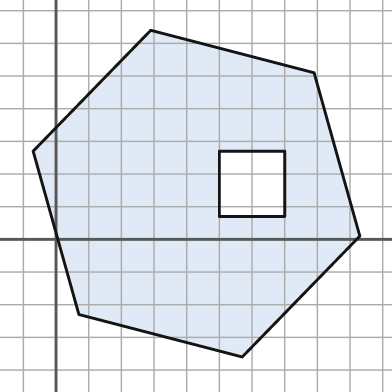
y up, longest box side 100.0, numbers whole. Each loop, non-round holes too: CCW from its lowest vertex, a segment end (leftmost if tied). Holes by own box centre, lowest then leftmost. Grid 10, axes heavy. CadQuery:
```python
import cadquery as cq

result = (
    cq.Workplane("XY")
    .moveTo(57.0, -36.0)
    .lineTo(93.0, 1.0)
    .lineTo(79.0, 51.0)
    .lineTo(29.0, 64.0)
    .lineTo(-7.0, 27.0)
    .lineTo(7.0, -23.0)
    .close()
    .moveTo(50.0, 7.0)
    .lineTo(70.0, 7.0)
    .lineTo(70.0, 27.0)
    .lineTo(50.0, 27.0)
    .close()
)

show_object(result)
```